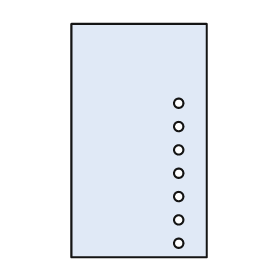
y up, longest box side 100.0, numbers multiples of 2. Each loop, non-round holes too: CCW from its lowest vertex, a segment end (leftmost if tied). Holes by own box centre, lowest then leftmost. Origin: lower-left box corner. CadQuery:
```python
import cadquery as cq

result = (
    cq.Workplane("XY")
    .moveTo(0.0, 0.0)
    .lineTo(58.0, 0.0)
    .lineTo(58.0, 100.0)
    .lineTo(0.0, 100.0)
    .close()
    .moveTo(46.0, 6.0)
    .circle(2.0)
    .moveTo(46.0, 16.0)
    .circle(2.0)
    .moveTo(46.0, 26.0)
    .circle(2.0)
    .moveTo(46.0, 36.0)
    .circle(2.0)
    .moveTo(46.0, 46.0)
    .circle(2.0)
    .moveTo(46.0, 56.0)
    .circle(2.0)
    .moveTo(46.0, 66.0)
    .circle(2.0)
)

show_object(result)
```